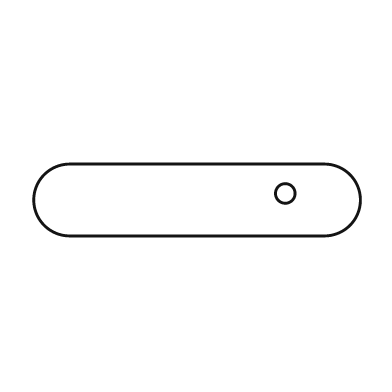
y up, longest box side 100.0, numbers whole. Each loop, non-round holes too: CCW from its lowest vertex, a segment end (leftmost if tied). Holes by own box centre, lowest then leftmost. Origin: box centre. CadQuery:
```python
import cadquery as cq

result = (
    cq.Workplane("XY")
    .moveTo(-39.0, -11.0)
    .lineTo(39.0, -11.0)
    .threePointArc((50.0, 0.0), (39.0, 11.0))
    .lineTo(-39.0, 11.0)
    .threePointArc((-50.0, 0.0), (-39.0, -11.0))
    .close()
    .moveTo(27.0, 2.0)
    .circle(3.0)
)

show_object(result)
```